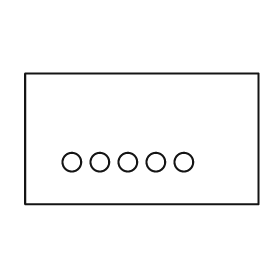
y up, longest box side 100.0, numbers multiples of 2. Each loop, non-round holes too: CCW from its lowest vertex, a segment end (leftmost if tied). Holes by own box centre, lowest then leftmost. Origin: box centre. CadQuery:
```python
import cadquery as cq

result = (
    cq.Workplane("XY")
    .moveTo(-50.0, -28.0)
    .lineTo(50.0, -28.0)
    .lineTo(50.0, 28.0)
    .lineTo(-50.0, 28.0)
    .close()
    .moveTo(-30.0, -10.0)
    .circle(4.0)
    .moveTo(-18.0, -10.0)
    .circle(4.0)
    .moveTo(-6.0, -10.0)
    .circle(4.0)
    .moveTo(6.0, -10.0)
    .circle(4.0)
    .moveTo(18.0, -10.0)
    .circle(4.0)
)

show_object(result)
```